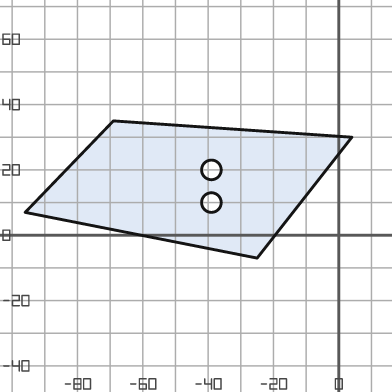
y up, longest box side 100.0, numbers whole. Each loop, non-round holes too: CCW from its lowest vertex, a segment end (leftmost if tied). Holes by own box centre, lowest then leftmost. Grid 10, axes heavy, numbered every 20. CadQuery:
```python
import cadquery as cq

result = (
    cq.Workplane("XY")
    .moveTo(-25.0, -7.0)
    .lineTo(4.0, 30.0)
    .lineTo(-69.0, 35.0)
    .lineTo(-96.0, 7.0)
    .close()
    .moveTo(-39.0, 10.0)
    .circle(3.0)
    .moveTo(-39.0, 20.0)
    .circle(3.0)
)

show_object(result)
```